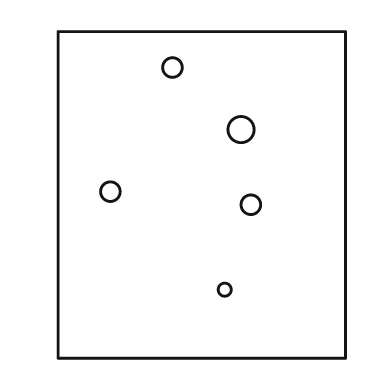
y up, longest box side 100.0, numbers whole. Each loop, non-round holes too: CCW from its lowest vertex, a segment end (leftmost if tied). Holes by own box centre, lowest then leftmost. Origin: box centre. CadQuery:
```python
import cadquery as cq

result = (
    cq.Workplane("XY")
    .moveTo(-44.0, -50.0)
    .lineTo(44.0, -50.0)
    .lineTo(44.0, 50.0)
    .lineTo(-44.0, 50.0)
    .close()
    .moveTo(7.0, -29.0)
    .circle(2.0)
    .moveTo(15.0, -3.0)
    .circle(3.0)
    .moveTo(-28.0, 1.0)
    .circle(3.0)
    .moveTo(12.0, 20.0)
    .circle(4.0)
    .moveTo(-9.0, 39.0)
    .circle(3.0)
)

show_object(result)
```